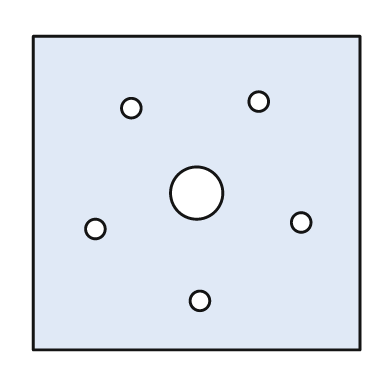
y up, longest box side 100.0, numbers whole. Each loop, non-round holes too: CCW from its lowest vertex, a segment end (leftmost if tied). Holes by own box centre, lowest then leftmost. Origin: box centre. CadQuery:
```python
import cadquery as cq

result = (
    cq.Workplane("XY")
    .moveTo(-50.0, -48.0)
    .lineTo(50.0, -48.0)
    .lineTo(50.0, 48.0)
    .lineTo(-50.0, 48.0)
    .close()
    .moveTo(1.0, -33.0)
    .circle(3.0)
    .moveTo(-31.0, -11.0)
    .circle(3.0)
    .moveTo(32.0, -9.0)
    .circle(3.0)
    .moveTo(0.0, 0.0)
    .circle(8.0)
    .moveTo(-20.0, 26.0)
    .circle(3.0)
    .moveTo(19.0, 28.0)
    .circle(3.0)
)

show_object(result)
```